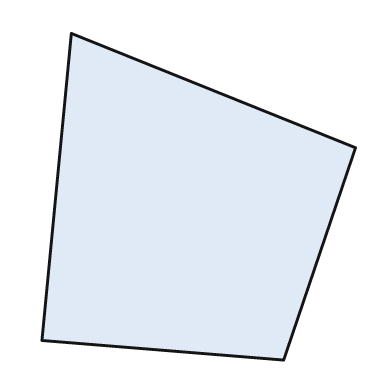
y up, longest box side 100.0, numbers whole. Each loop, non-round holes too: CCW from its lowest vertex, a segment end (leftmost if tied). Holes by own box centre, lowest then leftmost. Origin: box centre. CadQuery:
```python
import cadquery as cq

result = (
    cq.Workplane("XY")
    .moveTo(26.0, -50.0)
    .lineTo(48.0, 15.0)
    .lineTo(-39.0, 50.0)
    .lineTo(-48.0, -44.0)
    .close()
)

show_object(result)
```